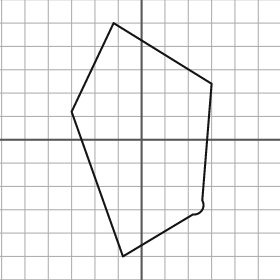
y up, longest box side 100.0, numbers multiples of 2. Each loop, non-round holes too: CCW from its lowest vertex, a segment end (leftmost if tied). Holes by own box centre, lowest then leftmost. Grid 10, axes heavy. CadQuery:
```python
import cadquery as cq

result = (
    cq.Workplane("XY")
    .moveTo(-8.0, -50.0)
    .lineTo(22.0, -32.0)
    .threePointArc((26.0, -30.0), (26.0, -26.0))
    .lineTo(30.0, 24.0)
    .lineTo(-12.0, 50.0)
    .lineTo(-30.0, 12.0)
    .close()
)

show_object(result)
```